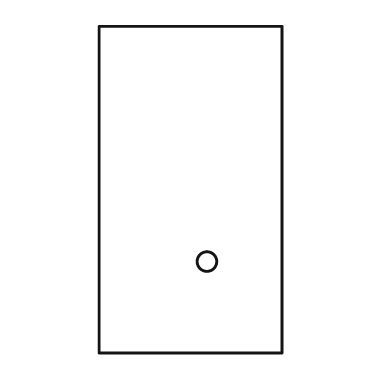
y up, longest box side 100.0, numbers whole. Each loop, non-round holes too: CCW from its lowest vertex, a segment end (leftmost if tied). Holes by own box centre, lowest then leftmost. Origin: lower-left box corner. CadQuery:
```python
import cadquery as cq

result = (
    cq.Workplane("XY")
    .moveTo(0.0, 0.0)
    .lineTo(56.0, 0.0)
    .lineTo(56.0, 100.0)
    .lineTo(0.0, 100.0)
    .close()
    .moveTo(33.0, 28.0)
    .circle(3.0)
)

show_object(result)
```